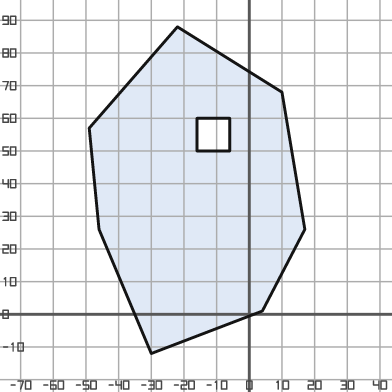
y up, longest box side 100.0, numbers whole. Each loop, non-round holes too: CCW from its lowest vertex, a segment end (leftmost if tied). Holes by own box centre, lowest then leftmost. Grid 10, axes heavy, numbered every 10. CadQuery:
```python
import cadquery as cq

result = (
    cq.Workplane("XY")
    .moveTo(-30.0, -12.0)
    .lineTo(4.0, 1.0)
    .lineTo(17.0, 26.0)
    .lineTo(10.0, 68.0)
    .lineTo(-22.0, 88.0)
    .lineTo(-49.0, 57.0)
    .lineTo(-46.0, 26.0)
    .close()
    .moveTo(-16.0, 50.0)
    .lineTo(-6.0, 50.0)
    .lineTo(-6.0, 60.0)
    .lineTo(-16.0, 60.0)
    .close()
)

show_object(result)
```